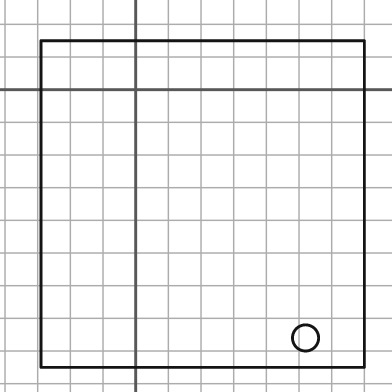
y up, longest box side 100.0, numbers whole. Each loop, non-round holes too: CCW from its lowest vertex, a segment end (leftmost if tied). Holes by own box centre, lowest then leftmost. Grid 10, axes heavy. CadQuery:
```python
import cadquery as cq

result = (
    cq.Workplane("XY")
    .moveTo(-29.0, -85.0)
    .lineTo(70.0, -85.0)
    .lineTo(70.0, 15.0)
    .lineTo(-29.0, 15.0)
    .close()
    .moveTo(52.0, -76.0)
    .circle(4.0)
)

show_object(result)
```